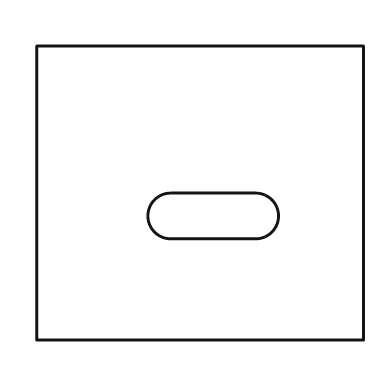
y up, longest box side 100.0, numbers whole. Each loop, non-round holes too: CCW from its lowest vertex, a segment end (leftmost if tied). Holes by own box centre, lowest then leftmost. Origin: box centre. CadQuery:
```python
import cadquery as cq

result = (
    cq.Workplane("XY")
    .moveTo(-50.0, -45.0)
    .lineTo(50.0, -45.0)
    .lineTo(50.0, 45.0)
    .lineTo(-50.0, 45.0)
    .close()
    .moveTo(-9.0, -14.0)
    .lineTo(17.0, -14.0)
    .threePointArc((24.0, -7.0), (17.0, 0.0))
    .lineTo(-9.0, 0.0)
    .threePointArc((-16.0, -7.0), (-9.0, -14.0))
    .close()
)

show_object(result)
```